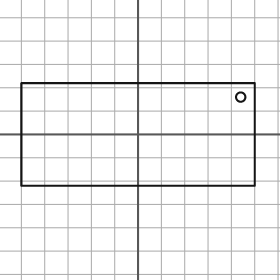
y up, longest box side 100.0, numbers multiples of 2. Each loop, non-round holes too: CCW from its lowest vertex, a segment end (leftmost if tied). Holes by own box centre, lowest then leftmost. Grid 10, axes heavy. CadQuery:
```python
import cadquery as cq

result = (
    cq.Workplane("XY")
    .moveTo(-50.0, -22.0)
    .lineTo(50.0, -22.0)
    .lineTo(50.0, 22.0)
    .lineTo(-50.0, 22.0)
    .close()
    .moveTo(44.0, 16.0)
    .circle(2.0)
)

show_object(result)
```